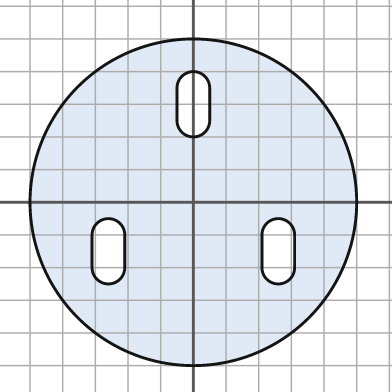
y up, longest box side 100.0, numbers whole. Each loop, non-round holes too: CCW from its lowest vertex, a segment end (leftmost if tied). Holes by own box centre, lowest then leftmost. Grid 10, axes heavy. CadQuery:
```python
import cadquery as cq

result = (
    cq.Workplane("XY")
    .moveTo(0.0, 0.0)
    .circle(50.0)
    .moveTo(-31.0, -20.0)
    .threePointArc((-26.0, -25.0), (-21.0, -20.0))
    .lineTo(-21.0, -10.0)
    .threePointArc((-26.0, -5.0), (-31.0, -10.0))
    .close()
    .moveTo(21.0, -20.0)
    .threePointArc((26.0, -25.0), (31.0, -20.0))
    .lineTo(31.0, -10.0)
    .threePointArc((26.0, -5.0), (21.0, -10.0))
    .close()
    .moveTo(-5.0, 25.0)
    .threePointArc((0.0, 20.0), (5.0, 25.0))
    .lineTo(5.0, 35.0)
    .threePointArc((0.0, 40.0), (-5.0, 35.0))
    .close()
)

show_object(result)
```